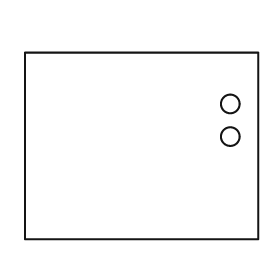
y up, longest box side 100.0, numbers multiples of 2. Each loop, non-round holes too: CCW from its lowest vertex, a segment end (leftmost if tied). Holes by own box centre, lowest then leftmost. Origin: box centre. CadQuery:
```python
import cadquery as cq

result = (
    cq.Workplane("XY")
    .moveTo(-50.0, -40.0)
    .lineTo(50.0, -40.0)
    .lineTo(50.0, 40.0)
    .lineTo(-50.0, 40.0)
    .close()
    .moveTo(38.0, 4.0)
    .circle(4.0)
    .moveTo(38.0, 18.0)
    .circle(4.0)
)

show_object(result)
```